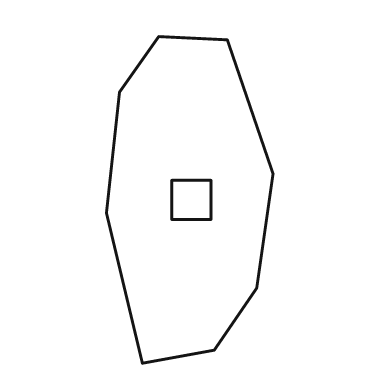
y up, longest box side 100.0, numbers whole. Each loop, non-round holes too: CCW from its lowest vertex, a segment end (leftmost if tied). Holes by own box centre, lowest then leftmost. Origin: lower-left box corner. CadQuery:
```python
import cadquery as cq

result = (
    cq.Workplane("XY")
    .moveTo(11.0, 0.0)
    .lineTo(33.0, 4.0)
    .lineTo(46.0, 23.0)
    .lineTo(51.0, 58.0)
    .lineTo(37.0, 99.0)
    .lineTo(16.0, 100.0)
    .lineTo(4.0, 83.0)
    .lineTo(0.0, 46.0)
    .close()
    .moveTo(20.0, 44.0)
    .lineTo(32.0, 44.0)
    .lineTo(32.0, 56.0)
    .lineTo(20.0, 56.0)
    .close()
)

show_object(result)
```